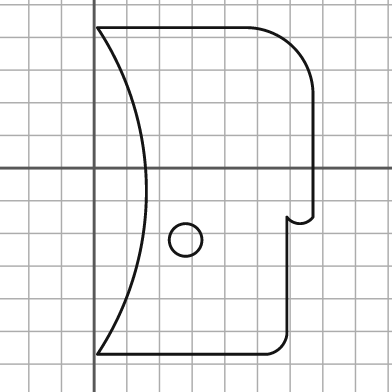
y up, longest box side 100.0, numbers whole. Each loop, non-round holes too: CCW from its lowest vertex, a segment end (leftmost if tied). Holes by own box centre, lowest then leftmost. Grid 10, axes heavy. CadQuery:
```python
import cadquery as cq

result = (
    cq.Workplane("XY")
    .moveTo(1.0, -57.0)
    .lineTo(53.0, -57.0)
    .threePointArc((57.0, -55.0), (59.0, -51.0))
    .lineTo(59.0, -15.0)
    .threePointArc((63.0, -17.0), (67.0, -15.0))
    .lineTo(67.0, 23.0)
    .threePointArc((61.0, 37.0), (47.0, 43.0))
    .lineTo(1.0, 43.0)
    .threePointArc((16.0, -7.0), (1.0, -57.0))
    .close()
    .moveTo(28.0, -22.0)
    .circle(5.0)
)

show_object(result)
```